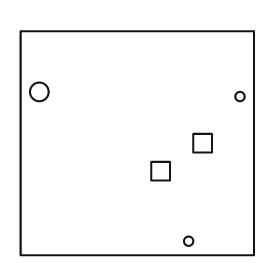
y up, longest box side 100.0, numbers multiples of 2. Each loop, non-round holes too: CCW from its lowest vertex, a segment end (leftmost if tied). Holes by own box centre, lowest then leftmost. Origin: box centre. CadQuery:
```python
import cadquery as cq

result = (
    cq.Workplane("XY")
    .moveTo(-50.0, -48.0)
    .lineTo(50.0, -48.0)
    .lineTo(50.0, 48.0)
    .lineTo(-50.0, 48.0)
    .close()
    .moveTo(22.0, -42.0)
    .circle(2.0)
    .moveTo(6.0, -16.0)
    .lineTo(14.0, -16.0)
    .lineTo(14.0, -8.0)
    .lineTo(6.0, -8.0)
    .close()
    .moveTo(24.0, -4.0)
    .lineTo(32.0, -4.0)
    .lineTo(32.0, 4.0)
    .lineTo(24.0, 4.0)
    .close()
    .moveTo(44.0, 20.0)
    .circle(2.0)
    .moveTo(-42.0, 22.0)
    .circle(4.0)
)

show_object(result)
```